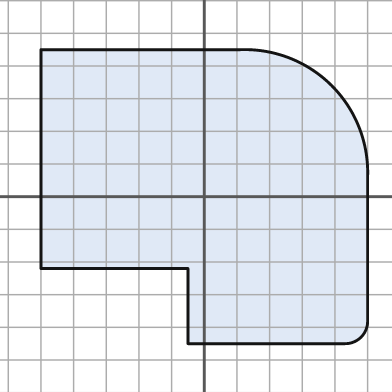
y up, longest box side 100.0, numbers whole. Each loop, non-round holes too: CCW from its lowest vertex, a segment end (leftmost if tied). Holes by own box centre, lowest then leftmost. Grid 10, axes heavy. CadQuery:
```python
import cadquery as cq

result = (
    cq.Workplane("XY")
    .moveTo(-5.0, -45.0)
    .lineTo(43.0, -45.0)
    .threePointArc((48.0, -43.0), (50.0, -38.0))
    .lineTo(50.0, 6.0)
    .threePointArc((39.0, 34.0), (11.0, 45.0))
    .lineTo(-50.0, 45.0)
    .lineTo(-50.0, -22.0)
    .lineTo(-5.0, -22.0)
    .close()
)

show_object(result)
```